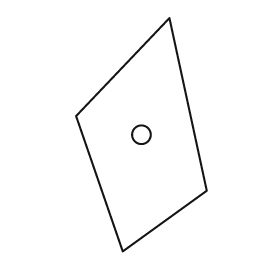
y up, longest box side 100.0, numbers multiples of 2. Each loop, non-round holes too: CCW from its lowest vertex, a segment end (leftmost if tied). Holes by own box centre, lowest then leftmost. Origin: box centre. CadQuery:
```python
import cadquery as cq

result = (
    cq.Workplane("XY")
    .moveTo(-8.0, -50.0)
    .lineTo(28.0, -24.0)
    .lineTo(12.0, 50.0)
    .lineTo(-28.0, 8.0)
    .close()
    .moveTo(0.0, 0.0)
    .circle(4.0)
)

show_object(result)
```